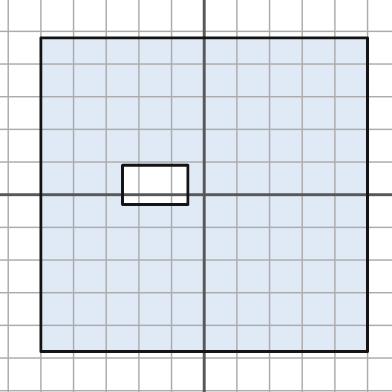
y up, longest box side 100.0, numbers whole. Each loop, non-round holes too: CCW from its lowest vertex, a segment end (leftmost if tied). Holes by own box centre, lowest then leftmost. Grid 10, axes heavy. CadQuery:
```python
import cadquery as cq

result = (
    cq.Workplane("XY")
    .moveTo(-50.0, -48.0)
    .lineTo(50.0, -48.0)
    .lineTo(50.0, 48.0)
    .lineTo(-50.0, 48.0)
    .close()
    .moveTo(-25.0, -3.0)
    .lineTo(-5.0, -3.0)
    .lineTo(-5.0, 9.0)
    .lineTo(-25.0, 9.0)
    .close()
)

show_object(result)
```